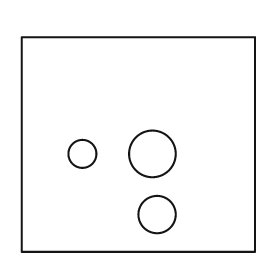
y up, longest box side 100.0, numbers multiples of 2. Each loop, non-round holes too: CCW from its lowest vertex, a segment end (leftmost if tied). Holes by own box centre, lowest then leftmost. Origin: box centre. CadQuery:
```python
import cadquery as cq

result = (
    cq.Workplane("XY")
    .moveTo(-50.0, -46.0)
    .lineTo(50.0, -46.0)
    .lineTo(50.0, 46.0)
    .lineTo(-50.0, 46.0)
    .close()
    .moveTo(8.0, -30.0)
    .circle(8.0)
    .moveTo(-24.0, -4.0)
    .circle(6.0)
    .moveTo(6.0, -4.0)
    .circle(10.0)
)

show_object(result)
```